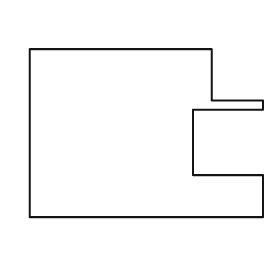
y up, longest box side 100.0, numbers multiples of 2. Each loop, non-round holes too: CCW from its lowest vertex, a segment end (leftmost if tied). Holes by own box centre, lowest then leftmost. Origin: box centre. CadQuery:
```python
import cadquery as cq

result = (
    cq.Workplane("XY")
    .moveTo(-50.0, -36.0)
    .lineTo(50.0, -36.0)
    .lineTo(50.0, -18.0)
    .lineTo(20.0, -18.0)
    .lineTo(20.0, 10.0)
    .lineTo(50.0, 10.0)
    .lineTo(50.0, 14.0)
    .lineTo(28.0, 14.0)
    .lineTo(28.0, 36.0)
    .lineTo(-50.0, 36.0)
    .close()
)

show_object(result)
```